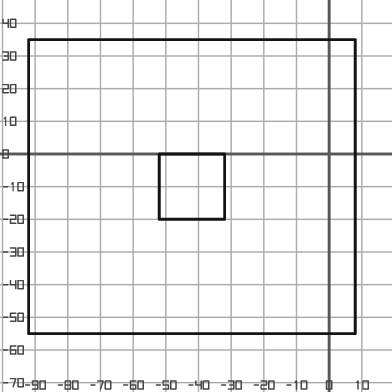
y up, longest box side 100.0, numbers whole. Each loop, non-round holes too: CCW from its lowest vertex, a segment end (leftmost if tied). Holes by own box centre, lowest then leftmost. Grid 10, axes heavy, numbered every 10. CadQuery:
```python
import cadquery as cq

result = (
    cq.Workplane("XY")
    .moveTo(-92.0, -55.0)
    .lineTo(8.0, -55.0)
    .lineTo(8.0, 35.0)
    .lineTo(-92.0, 35.0)
    .close()
    .moveTo(-52.0, -20.0)
    .lineTo(-32.0, -20.0)
    .lineTo(-32.0, 0.0)
    .lineTo(-52.0, 0.0)
    .close()
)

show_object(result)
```